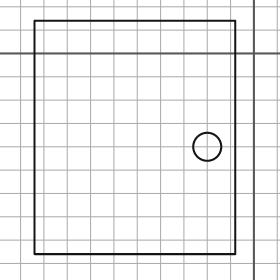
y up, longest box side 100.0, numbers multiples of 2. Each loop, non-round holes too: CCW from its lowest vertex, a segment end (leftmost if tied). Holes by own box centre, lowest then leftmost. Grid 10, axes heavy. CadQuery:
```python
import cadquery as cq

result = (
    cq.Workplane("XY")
    .moveTo(-94.0, -86.0)
    .lineTo(-8.0, -86.0)
    .lineTo(-8.0, 14.0)
    .lineTo(-94.0, 14.0)
    .close()
    .moveTo(-20.0, -40.0)
    .circle(6.0)
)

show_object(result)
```